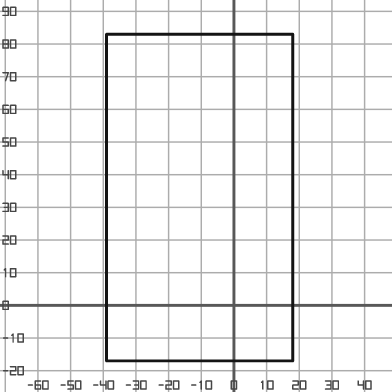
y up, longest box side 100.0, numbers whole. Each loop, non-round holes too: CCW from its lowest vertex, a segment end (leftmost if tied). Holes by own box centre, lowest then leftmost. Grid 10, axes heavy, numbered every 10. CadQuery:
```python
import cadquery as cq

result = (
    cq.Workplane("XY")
    .moveTo(-39.0, -17.0)
    .lineTo(18.0, -17.0)
    .lineTo(18.0, 83.0)
    .lineTo(-39.0, 83.0)
    .close()
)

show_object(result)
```